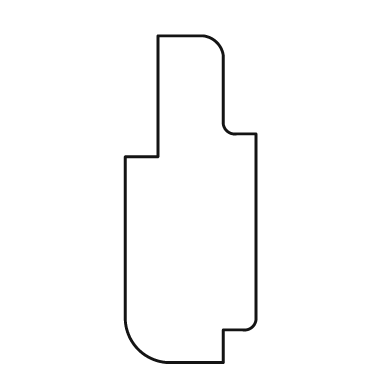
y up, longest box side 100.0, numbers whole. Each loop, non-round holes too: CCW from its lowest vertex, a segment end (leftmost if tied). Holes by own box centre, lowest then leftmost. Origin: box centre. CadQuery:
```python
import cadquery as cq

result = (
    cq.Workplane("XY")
    .moveTo(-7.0, -50.0)
    .lineTo(10.0, -50.0)
    .lineTo(10.0, -40.0)
    .lineTo(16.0, -40.0)
    .threePointArc((19.0, -39.0), (20.0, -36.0))
    .lineTo(20.0, 20.0)
    .lineTo(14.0, 20.0)
    .threePointArc((11.0, 21.0), (10.0, 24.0))
    .lineTo(10.0, 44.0)
    .threePointArc((8.0, 48.0), (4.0, 50.0))
    .lineTo(-10.0, 50.0)
    .lineTo(-10.0, 13.0)
    .lineTo(-20.0, 13.0)
    .lineTo(-20.0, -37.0)
    .threePointArc((-16.0, -46.0), (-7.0, -50.0))
    .close()
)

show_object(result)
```